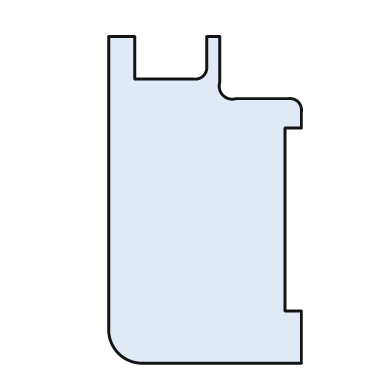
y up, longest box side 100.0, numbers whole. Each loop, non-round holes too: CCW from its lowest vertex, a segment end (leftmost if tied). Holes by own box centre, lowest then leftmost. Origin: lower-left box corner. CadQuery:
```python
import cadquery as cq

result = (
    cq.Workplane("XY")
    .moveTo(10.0, 0.0)
    .lineTo(59.0, 0.0)
    .lineTo(59.0, 16.0)
    .lineTo(54.0, 16.0)
    .lineTo(54.0, 72.0)
    .lineTo(59.0, 72.0)
    .lineTo(59.0, 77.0)
    .threePointArc((58.0, 80.0), (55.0, 81.0))
    .lineTo(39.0, 81.0)
    .threePointArc((35.0, 82.0), (34.0, 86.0))
    .lineTo(34.0, 100.0)
    .lineTo(30.0, 100.0)
    .lineTo(30.0, 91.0)
    .threePointArc((29.0, 88.0), (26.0, 87.0))
    .lineTo(8.0, 87.0)
    .lineTo(8.0, 100.0)
    .lineTo(0.0, 100.0)
    .lineTo(0.0, 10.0)
    .threePointArc((3.0, 3.0), (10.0, 0.0))
    .close()
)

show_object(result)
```